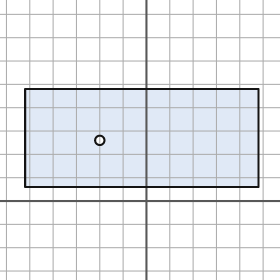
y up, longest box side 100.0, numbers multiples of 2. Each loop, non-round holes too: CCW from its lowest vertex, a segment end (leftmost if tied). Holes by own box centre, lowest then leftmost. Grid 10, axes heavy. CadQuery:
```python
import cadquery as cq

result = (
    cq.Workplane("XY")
    .moveTo(-52.0, 6.0)
    .lineTo(48.0, 6.0)
    .lineTo(48.0, 48.0)
    .lineTo(-52.0, 48.0)
    .close()
    .moveTo(-20.0, 26.0)
    .circle(2.0)
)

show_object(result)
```